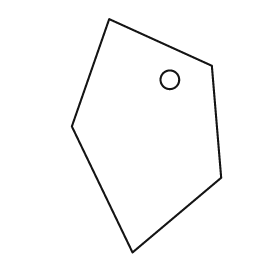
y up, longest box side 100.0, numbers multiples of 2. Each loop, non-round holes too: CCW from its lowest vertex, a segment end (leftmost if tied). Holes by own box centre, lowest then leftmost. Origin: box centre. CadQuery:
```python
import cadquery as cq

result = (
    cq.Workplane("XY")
    .moveTo(-6.0, -50.0)
    .lineTo(32.0, -18.0)
    .lineTo(28.0, 30.0)
    .lineTo(-16.0, 50.0)
    .lineTo(-32.0, 4.0)
    .close()
    .moveTo(10.0, 24.0)
    .circle(4.0)
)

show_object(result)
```